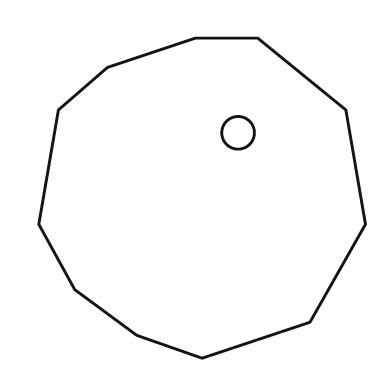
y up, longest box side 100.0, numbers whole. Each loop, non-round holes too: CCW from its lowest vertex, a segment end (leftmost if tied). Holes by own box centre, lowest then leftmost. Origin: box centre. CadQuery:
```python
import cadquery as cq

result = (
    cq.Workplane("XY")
    .moveTo(0.0, -49.0)
    .lineTo(33.0, -38.0)
    .lineTo(50.0, -8.0)
    .lineTo(44.0, 27.0)
    .lineTo(17.0, 49.0)
    .lineTo(-2.0, 49.0)
    .lineTo(-29.0, 40.0)
    .lineTo(-44.0, 27.0)
    .lineTo(-50.0, -8.0)
    .lineTo(-39.0, -28.0)
    .lineTo(-20.0, -42.0)
    .close()
    .moveTo(11.0, 20.0)
    .circle(5.0)
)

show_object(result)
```